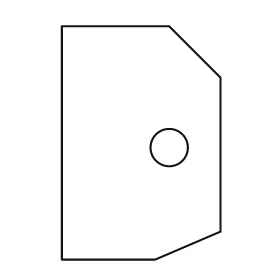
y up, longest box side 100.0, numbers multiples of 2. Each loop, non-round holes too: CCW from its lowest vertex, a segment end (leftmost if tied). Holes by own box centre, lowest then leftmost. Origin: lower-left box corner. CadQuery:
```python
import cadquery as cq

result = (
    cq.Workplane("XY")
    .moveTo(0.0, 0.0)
    .lineTo(40.0, 0.0)
    .lineTo(68.0, 12.0)
    .lineTo(68.0, 78.0)
    .lineTo(46.0, 100.0)
    .lineTo(0.0, 100.0)
    .close()
    .moveTo(46.0, 48.0)
    .circle(8.0)
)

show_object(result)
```